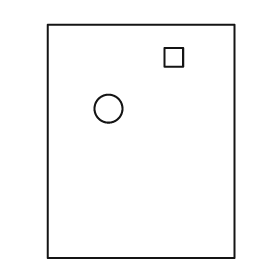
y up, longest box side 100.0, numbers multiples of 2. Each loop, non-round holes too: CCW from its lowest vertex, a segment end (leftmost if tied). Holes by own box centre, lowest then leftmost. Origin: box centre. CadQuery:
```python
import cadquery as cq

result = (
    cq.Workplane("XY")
    .moveTo(-40.0, -50.0)
    .lineTo(40.0, -50.0)
    .lineTo(40.0, 50.0)
    .lineTo(-40.0, 50.0)
    .close()
    .moveTo(-14.0, 14.0)
    .circle(6.0)
    .moveTo(10.0, 32.0)
    .lineTo(18.0, 32.0)
    .lineTo(18.0, 40.0)
    .lineTo(10.0, 40.0)
    .close()
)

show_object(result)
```